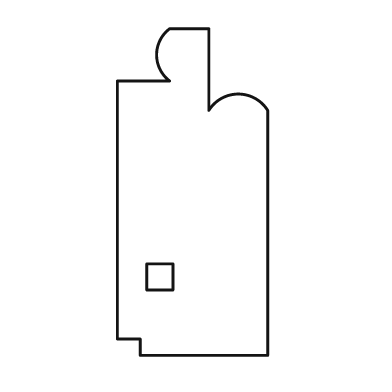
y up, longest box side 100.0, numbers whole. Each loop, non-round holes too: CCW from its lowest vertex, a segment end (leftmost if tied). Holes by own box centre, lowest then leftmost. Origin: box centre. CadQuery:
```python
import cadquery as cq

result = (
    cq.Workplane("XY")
    .moveTo(-16.0, -50.0)
    .lineTo(23.0, -50.0)
    .lineTo(23.0, 25.0)
    .threePointArc((14.0, 30.0), (5.0, 25.0))
    .lineTo(5.0, 50.0)
    .lineTo(-7.0, 50.0)
    .threePointArc((-11.0, 42.0), (-7.0, 34.0))
    .lineTo(-23.0, 34.0)
    .lineTo(-23.0, -45.0)
    .lineTo(-16.0, -45.0)
    .close()
    .moveTo(-14.0, -30.0)
    .lineTo(-6.0, -30.0)
    .lineTo(-6.0, -22.0)
    .lineTo(-14.0, -22.0)
    .close()
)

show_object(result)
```